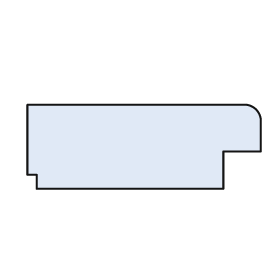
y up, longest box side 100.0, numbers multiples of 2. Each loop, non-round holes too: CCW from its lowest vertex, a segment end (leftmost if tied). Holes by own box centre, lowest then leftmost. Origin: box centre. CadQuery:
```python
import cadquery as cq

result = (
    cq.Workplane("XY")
    .moveTo(-46.0, -18.0)
    .lineTo(34.0, -18.0)
    .lineTo(34.0, -2.0)
    .lineTo(50.0, -2.0)
    .lineTo(50.0, 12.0)
    .threePointArc((48.0, 16.0), (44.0, 18.0))
    .lineTo(-50.0, 18.0)
    .lineTo(-50.0, -12.0)
    .lineTo(-46.0, -12.0)
    .close()
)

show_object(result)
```